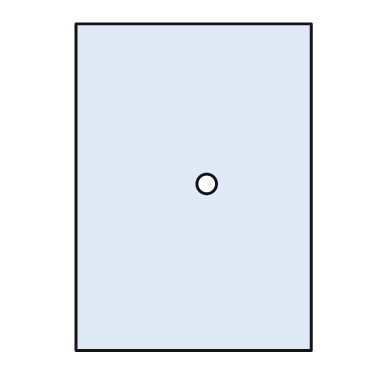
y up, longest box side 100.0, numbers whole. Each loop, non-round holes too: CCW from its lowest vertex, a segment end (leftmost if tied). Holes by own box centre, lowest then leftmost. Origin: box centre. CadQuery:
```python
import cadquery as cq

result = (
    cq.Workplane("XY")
    .moveTo(-36.0, -50.0)
    .lineTo(36.0, -50.0)
    .lineTo(36.0, 50.0)
    .lineTo(-36.0, 50.0)
    .close()
    .moveTo(4.0, 1.0)
    .circle(3.0)
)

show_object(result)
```